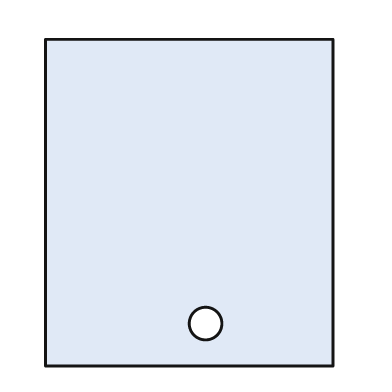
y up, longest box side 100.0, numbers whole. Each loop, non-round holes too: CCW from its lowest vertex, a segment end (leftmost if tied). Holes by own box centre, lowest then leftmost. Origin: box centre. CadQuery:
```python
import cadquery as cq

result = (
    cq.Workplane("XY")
    .moveTo(-44.0, -50.0)
    .lineTo(44.0, -50.0)
    .lineTo(44.0, 50.0)
    .lineTo(-44.0, 50.0)
    .close()
    .moveTo(5.0, -37.0)
    .circle(5.0)
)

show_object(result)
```